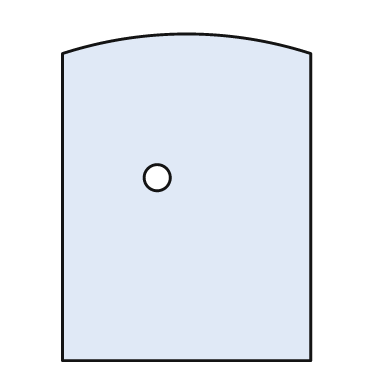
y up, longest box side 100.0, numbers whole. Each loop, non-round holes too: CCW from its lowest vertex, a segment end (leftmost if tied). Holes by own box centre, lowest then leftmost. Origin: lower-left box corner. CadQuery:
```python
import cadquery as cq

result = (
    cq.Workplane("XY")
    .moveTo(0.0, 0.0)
    .lineTo(76.0, 0.0)
    .lineTo(76.0, 94.0)
    .threePointArc((38.0, 100.0), (0.0, 94.0))
    .close()
    .moveTo(29.0, 56.0)
    .circle(4.0)
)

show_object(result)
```